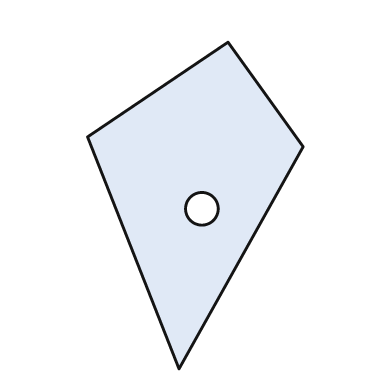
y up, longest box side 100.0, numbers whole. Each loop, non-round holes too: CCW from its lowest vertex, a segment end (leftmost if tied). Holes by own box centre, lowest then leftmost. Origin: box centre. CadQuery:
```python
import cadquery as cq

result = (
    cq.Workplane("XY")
    .moveTo(-5.0, -50.0)
    .lineTo(33.0, 18.0)
    .lineTo(10.0, 50.0)
    .lineTo(-33.0, 21.0)
    .close()
    .moveTo(2.0, -1.0)
    .circle(5.0)
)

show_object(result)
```